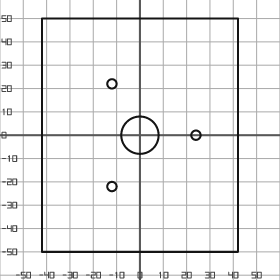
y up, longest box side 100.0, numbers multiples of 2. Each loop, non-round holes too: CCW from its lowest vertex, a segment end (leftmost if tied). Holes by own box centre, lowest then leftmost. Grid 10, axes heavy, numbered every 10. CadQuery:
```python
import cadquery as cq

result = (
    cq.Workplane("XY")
    .moveTo(-42.0, -50.0)
    .lineTo(42.0, -50.0)
    .lineTo(42.0, 50.0)
    .lineTo(-42.0, 50.0)
    .close()
    .moveTo(-12.0, -22.0)
    .circle(2.0)
    .moveTo(0.0, 0.0)
    .circle(8.0)
    .moveTo(24.0, 0.0)
    .circle(2.0)
    .moveTo(-12.0, 22.0)
    .circle(2.0)
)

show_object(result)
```